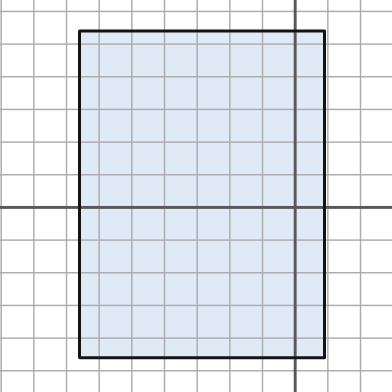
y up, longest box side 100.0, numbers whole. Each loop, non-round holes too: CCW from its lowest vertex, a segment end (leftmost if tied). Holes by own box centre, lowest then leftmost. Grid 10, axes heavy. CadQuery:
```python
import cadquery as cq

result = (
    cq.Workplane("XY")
    .moveTo(-66.0, -46.0)
    .lineTo(9.0, -46.0)
    .lineTo(9.0, 54.0)
    .lineTo(-66.0, 54.0)
    .close()
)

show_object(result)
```